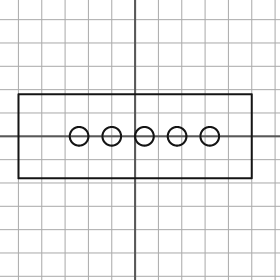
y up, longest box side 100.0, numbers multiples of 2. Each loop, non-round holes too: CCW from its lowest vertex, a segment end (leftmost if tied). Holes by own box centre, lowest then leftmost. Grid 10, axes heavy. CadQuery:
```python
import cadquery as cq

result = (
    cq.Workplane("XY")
    .moveTo(-50.0, -18.0)
    .lineTo(50.0, -18.0)
    .lineTo(50.0, 18.0)
    .lineTo(-50.0, 18.0)
    .close()
    .moveTo(-24.0, 0.0)
    .circle(4.0)
    .moveTo(-10.0, 0.0)
    .circle(4.0)
    .moveTo(4.0, 0.0)
    .circle(4.0)
    .moveTo(18.0, 0.0)
    .circle(4.0)
    .moveTo(32.0, 0.0)
    .circle(4.0)
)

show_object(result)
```